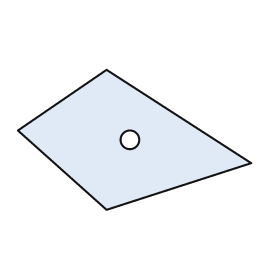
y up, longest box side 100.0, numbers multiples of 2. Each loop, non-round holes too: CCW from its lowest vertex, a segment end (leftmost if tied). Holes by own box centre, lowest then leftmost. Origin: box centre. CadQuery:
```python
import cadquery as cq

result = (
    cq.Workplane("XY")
    .moveTo(-12.0, -30.0)
    .lineTo(50.0, -10.0)
    .lineTo(-12.0, 30.0)
    .lineTo(-50.0, 4.0)
    .close()
    .moveTo(-2.0, 0.0)
    .circle(4.0)
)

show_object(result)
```